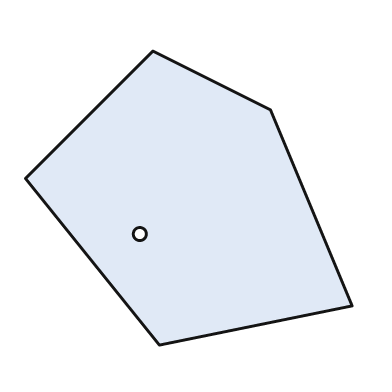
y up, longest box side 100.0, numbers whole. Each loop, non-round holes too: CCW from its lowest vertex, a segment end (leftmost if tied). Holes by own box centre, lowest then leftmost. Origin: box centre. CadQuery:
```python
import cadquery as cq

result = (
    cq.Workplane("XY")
    .moveTo(-9.0, -45.0)
    .lineTo(50.0, -33.0)
    .lineTo(25.0, 27.0)
    .lineTo(-11.0, 45.0)
    .lineTo(-50.0, 6.0)
    .close()
    .moveTo(-15.0, -11.0)
    .circle(2.0)
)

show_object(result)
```